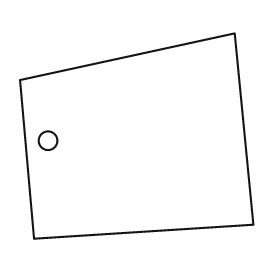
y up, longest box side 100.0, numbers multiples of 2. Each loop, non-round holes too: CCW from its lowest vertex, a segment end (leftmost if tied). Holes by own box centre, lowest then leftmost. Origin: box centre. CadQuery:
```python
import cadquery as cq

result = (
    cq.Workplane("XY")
    .moveTo(-44.0, -44.0)
    .lineTo(50.0, -38.0)
    .lineTo(42.0, 44.0)
    .lineTo(-50.0, 24.0)
    .close()
    .moveTo(-38.0, -2.0)
    .circle(4.0)
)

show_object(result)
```